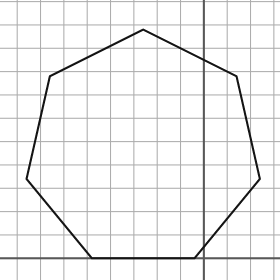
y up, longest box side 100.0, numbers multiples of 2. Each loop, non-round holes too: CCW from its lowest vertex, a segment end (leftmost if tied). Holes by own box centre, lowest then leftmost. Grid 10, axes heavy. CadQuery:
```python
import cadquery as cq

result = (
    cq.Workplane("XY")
    .moveTo(-48.0, 0.0)
    .lineTo(-4.0, 0.0)
    .lineTo(24.0, 34.0)
    .lineTo(14.0, 78.0)
    .lineTo(-26.0, 98.0)
    .lineTo(-66.0, 78.0)
    .lineTo(-76.0, 34.0)
    .close()
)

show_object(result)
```